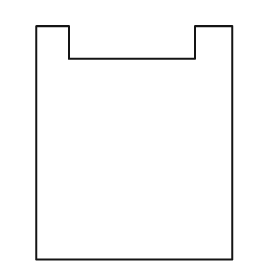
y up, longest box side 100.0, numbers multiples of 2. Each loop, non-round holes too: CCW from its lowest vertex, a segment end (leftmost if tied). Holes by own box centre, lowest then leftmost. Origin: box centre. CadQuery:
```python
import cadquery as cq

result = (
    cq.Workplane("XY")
    .moveTo(-42.0, -50.0)
    .lineTo(42.0, -50.0)
    .lineTo(42.0, 50.0)
    .lineTo(26.0, 50.0)
    .lineTo(26.0, 36.0)
    .lineTo(-28.0, 36.0)
    .lineTo(-28.0, 50.0)
    .lineTo(-42.0, 50.0)
    .close()
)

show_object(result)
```